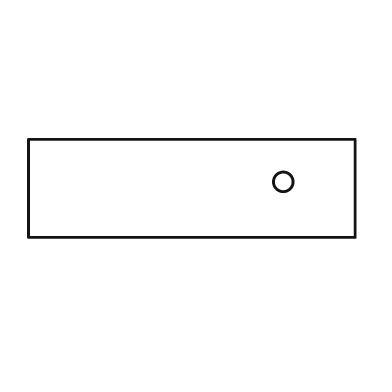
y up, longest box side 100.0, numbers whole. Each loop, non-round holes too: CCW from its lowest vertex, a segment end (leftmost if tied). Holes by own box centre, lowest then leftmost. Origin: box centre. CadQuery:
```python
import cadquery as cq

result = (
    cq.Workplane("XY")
    .moveTo(-50.0, -15.0)
    .lineTo(50.0, -15.0)
    .lineTo(50.0, 15.0)
    .lineTo(-50.0, 15.0)
    .close()
    .moveTo(28.0, 2.0)
    .circle(3.0)
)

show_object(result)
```